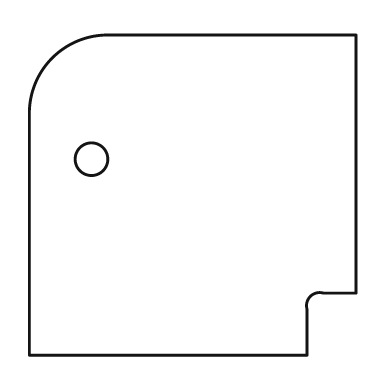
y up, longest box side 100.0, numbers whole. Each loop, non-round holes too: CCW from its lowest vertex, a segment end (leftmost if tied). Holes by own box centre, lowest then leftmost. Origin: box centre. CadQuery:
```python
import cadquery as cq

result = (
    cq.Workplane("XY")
    .moveTo(-50.0, -49.0)
    .lineTo(35.0, -49.0)
    .lineTo(35.0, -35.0)
    .threePointArc((36.0, -31.0), (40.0, -30.0))
    .lineTo(50.0, -30.0)
    .lineTo(50.0, 49.0)
    .lineTo(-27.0, 49.0)
    .threePointArc((-43.0, 42.0), (-50.0, 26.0))
    .close()
    .moveTo(-31.0, 11.0)
    .circle(5.0)
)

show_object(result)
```